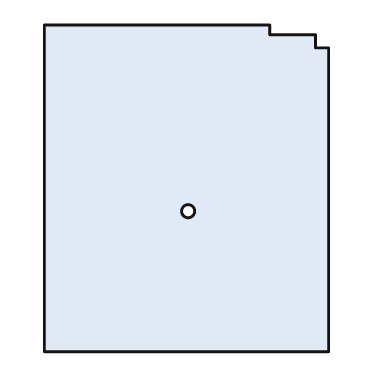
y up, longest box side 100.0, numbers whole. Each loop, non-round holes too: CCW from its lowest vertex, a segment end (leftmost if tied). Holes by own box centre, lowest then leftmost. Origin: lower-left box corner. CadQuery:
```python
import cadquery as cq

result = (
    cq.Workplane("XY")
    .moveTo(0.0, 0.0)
    .lineTo(87.0, 0.0)
    .lineTo(87.0, 93.0)
    .lineTo(83.0, 93.0)
    .lineTo(83.0, 97.0)
    .lineTo(69.0, 97.0)
    .lineTo(69.0, 100.0)
    .lineTo(0.0, 100.0)
    .close()
    .moveTo(44.0, 43.0)
    .circle(2.0)
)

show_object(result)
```